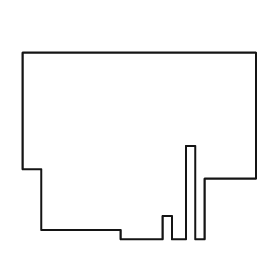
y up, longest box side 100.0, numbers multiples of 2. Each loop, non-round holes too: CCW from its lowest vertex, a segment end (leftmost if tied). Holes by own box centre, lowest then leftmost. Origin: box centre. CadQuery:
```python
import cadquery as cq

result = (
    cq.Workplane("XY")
    .moveTo(-8.0, -40.0)
    .lineTo(10.0, -40.0)
    .lineTo(10.0, -30.0)
    .lineTo(14.0, -30.0)
    .lineTo(14.0, -40.0)
    .lineTo(20.0, -40.0)
    .lineTo(20.0, 0.0)
    .lineTo(24.0, 0.0)
    .lineTo(24.0, -40.0)
    .lineTo(28.0, -40.0)
    .lineTo(28.0, -14.0)
    .lineTo(50.0, -14.0)
    .lineTo(50.0, 40.0)
    .lineTo(-50.0, 40.0)
    .lineTo(-50.0, -10.0)
    .lineTo(-42.0, -10.0)
    .lineTo(-42.0, -36.0)
    .lineTo(-8.0, -36.0)
    .close()
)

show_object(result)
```